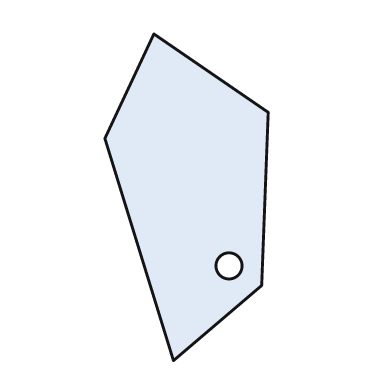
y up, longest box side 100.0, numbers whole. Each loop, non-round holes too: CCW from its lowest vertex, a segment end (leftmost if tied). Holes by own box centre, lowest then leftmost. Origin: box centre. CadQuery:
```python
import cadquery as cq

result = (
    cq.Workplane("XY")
    .moveTo(-4.0, -50.0)
    .lineTo(23.0, -27.0)
    .lineTo(25.0, 26.0)
    .lineTo(-10.0, 50.0)
    .lineTo(-25.0, 18.0)
    .close()
    .moveTo(13.0, -21.0)
    .circle(4.0)
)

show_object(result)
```